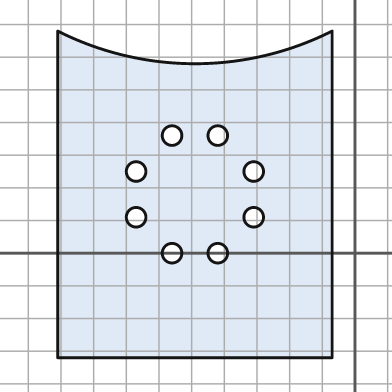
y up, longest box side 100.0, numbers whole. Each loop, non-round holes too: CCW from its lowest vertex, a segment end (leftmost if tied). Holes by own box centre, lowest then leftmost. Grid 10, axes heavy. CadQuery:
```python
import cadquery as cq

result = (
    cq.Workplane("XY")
    .moveTo(-91.0, -32.0)
    .lineTo(-7.0, -32.0)
    .lineTo(-7.0, 68.0)
    .threePointArc((-49.0, 58.0), (-91.0, 68.0))
    .close()
    .moveTo(-56.0, 0.0)
    .circle(3.0)
    .moveTo(-42.0, 0.0)
    .circle(3.0)
    .moveTo(-67.0, 11.0)
    .circle(3.0)
    .moveTo(-31.0, 11.0)
    .circle(3.0)
    .moveTo(-67.0, 25.0)
    .circle(3.0)
    .moveTo(-31.0, 25.0)
    .circle(3.0)
    .moveTo(-56.0, 36.0)
    .circle(3.0)
    .moveTo(-42.0, 36.0)
    .circle(3.0)
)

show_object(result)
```